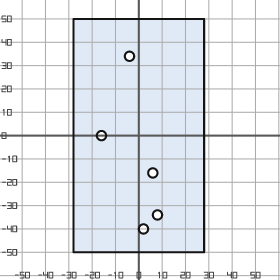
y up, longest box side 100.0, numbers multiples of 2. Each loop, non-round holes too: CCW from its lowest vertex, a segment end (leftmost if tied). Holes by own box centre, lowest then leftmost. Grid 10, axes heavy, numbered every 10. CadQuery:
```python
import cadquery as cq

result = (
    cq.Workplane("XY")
    .moveTo(-28.0, -50.0)
    .lineTo(28.0, -50.0)
    .lineTo(28.0, 50.0)
    .lineTo(-28.0, 50.0)
    .close()
    .moveTo(2.0, -40.0)
    .circle(2.0)
    .moveTo(8.0, -34.0)
    .circle(2.0)
    .moveTo(6.0, -16.0)
    .circle(2.0)
    .moveTo(-16.0, 0.0)
    .circle(2.0)
    .moveTo(-4.0, 34.0)
    .circle(2.0)
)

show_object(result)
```